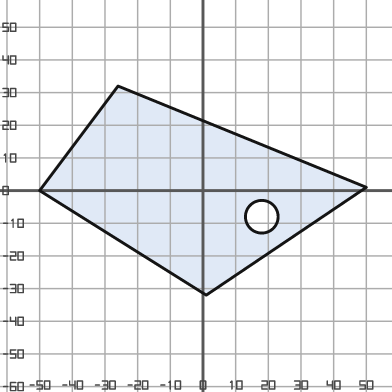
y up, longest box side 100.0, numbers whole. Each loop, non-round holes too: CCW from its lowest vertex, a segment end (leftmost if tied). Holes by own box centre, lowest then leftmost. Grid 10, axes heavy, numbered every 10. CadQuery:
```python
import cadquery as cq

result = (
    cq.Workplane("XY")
    .moveTo(1.0, -32.0)
    .lineTo(50.0, 1.0)
    .lineTo(-26.0, 32.0)
    .lineTo(-50.0, 0.0)
    .close()
    .moveTo(18.0, -8.0)
    .circle(5.0)
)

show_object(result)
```